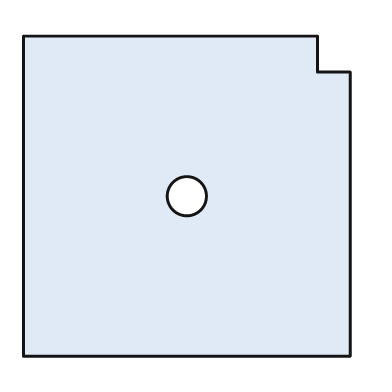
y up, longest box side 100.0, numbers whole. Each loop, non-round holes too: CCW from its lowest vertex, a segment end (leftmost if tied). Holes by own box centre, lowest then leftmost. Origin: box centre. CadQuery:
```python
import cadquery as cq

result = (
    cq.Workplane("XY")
    .moveTo(-50.0, -49.0)
    .lineTo(50.0, -49.0)
    .lineTo(50.0, 38.0)
    .lineTo(40.0, 38.0)
    .lineTo(40.0, 49.0)
    .lineTo(-50.0, 49.0)
    .close()
    .moveTo(0.0, 0.0)
    .circle(6.0)
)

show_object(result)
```